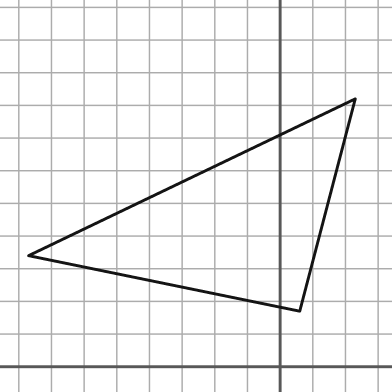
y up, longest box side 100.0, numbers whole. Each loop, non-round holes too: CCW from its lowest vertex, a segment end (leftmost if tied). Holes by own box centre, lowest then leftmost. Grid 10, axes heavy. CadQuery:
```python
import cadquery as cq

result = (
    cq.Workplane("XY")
    .moveTo(6.0, 17.0)
    .lineTo(23.0, 82.0)
    .lineTo(-77.0, 34.0)
    .close()
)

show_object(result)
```